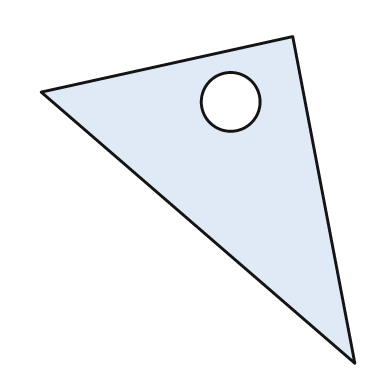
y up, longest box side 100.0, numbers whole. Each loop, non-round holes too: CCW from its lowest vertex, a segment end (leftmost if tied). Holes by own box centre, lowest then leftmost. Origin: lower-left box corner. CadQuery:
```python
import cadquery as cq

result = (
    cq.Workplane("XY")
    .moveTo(96.0, 0.0)
    .lineTo(77.0, 100.0)
    .lineTo(0.0, 83.0)
    .close()
    .moveTo(58.0, 80.0)
    .circle(9.0)
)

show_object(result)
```